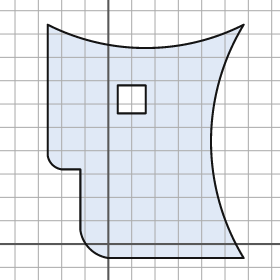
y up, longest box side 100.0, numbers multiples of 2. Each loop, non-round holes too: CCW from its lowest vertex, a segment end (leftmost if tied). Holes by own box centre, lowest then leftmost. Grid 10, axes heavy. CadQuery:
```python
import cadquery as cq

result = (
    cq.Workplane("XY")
    .moveTo(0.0, -6.0)
    .lineTo(58.0, -6.0)
    .threePointArc((44.0, 44.0), (58.0, 94.0))
    .threePointArc((16.0, 84.0), (-26.0, 94.0))
    .lineTo(-26.0, 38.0)
    .threePointArc((-24.0, 34.0), (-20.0, 32.0))
    .lineTo(-12.0, 32.0)
    .lineTo(-12.0, 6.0)
    .threePointArc((-8.0, -2.0), (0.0, -6.0))
    .close()
    .moveTo(4.0, 56.0)
    .lineTo(16.0, 56.0)
    .lineTo(16.0, 68.0)
    .lineTo(4.0, 68.0)
    .close()
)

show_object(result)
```